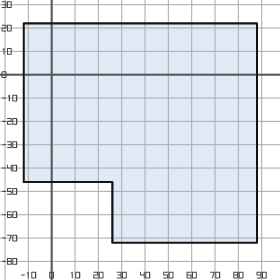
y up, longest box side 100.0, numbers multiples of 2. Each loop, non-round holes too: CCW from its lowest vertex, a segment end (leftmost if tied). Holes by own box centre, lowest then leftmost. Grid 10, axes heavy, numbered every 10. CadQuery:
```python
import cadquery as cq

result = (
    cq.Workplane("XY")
    .moveTo(26.0, -72.0)
    .lineTo(88.0, -72.0)
    .lineTo(88.0, 22.0)
    .lineTo(-12.0, 22.0)
    .lineTo(-12.0, -46.0)
    .lineTo(26.0, -46.0)
    .close()
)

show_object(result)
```